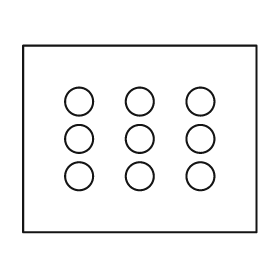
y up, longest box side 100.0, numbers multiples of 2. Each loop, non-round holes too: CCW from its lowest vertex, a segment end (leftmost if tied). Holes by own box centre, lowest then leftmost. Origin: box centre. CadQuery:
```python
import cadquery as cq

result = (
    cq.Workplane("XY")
    .moveTo(-50.0, -40.0)
    .lineTo(50.0, -40.0)
    .lineTo(50.0, 40.0)
    .lineTo(-50.0, 40.0)
    .close()
    .moveTo(-26.0, -16.0)
    .circle(6.0)
    .moveTo(0.0, -16.0)
    .circle(6.0)
    .moveTo(26.0, -16.0)
    .circle(6.0)
    .moveTo(-26.0, 0.0)
    .circle(6.0)
    .moveTo(0.0, 0.0)
    .circle(6.0)
    .moveTo(26.0, 0.0)
    .circle(6.0)
    .moveTo(-26.0, 16.0)
    .circle(6.0)
    .moveTo(0.0, 16.0)
    .circle(6.0)
    .moveTo(26.0, 16.0)
    .circle(6.0)
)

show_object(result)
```